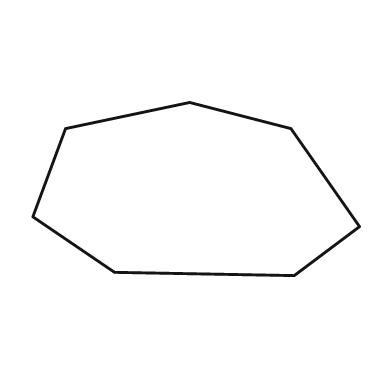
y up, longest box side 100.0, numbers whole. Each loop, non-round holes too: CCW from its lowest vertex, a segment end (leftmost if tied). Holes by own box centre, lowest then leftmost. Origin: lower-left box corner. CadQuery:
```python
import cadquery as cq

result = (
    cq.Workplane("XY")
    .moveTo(80.0, 0.0)
    .lineTo(100.0, 15.0)
    .lineTo(79.0, 45.0)
    .lineTo(48.0, 53.0)
    .lineTo(10.0, 45.0)
    .lineTo(0.0, 18.0)
    .lineTo(25.0, 1.0)
    .close()
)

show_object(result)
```